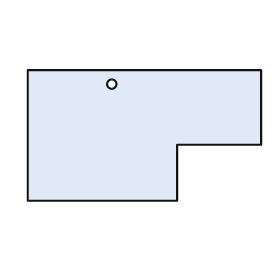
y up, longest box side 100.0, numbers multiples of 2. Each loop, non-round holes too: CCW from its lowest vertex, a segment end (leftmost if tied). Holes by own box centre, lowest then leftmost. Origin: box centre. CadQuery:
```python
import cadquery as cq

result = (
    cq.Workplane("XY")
    .moveTo(-50.0, -28.0)
    .lineTo(14.0, -28.0)
    .lineTo(14.0, -4.0)
    .lineTo(50.0, -4.0)
    .lineTo(50.0, 28.0)
    .lineTo(-50.0, 28.0)
    .close()
    .moveTo(-14.0, 22.0)
    .circle(2.0)
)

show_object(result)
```